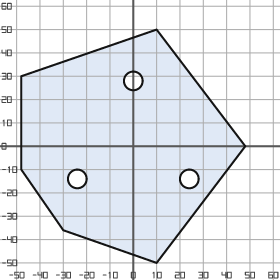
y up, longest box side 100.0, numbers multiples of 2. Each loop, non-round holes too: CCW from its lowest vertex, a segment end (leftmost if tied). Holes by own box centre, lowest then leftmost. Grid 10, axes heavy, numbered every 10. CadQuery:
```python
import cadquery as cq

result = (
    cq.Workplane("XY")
    .moveTo(10.0, -50.0)
    .lineTo(48.0, 0.0)
    .lineTo(10.0, 50.0)
    .lineTo(-48.0, 30.0)
    .lineTo(-48.0, -10.0)
    .lineTo(-30.0, -36.0)
    .close()
    .moveTo(-24.0, -14.0)
    .circle(4.0)
    .moveTo(24.0, -14.0)
    .circle(4.0)
    .moveTo(0.0, 28.0)
    .circle(4.0)
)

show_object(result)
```